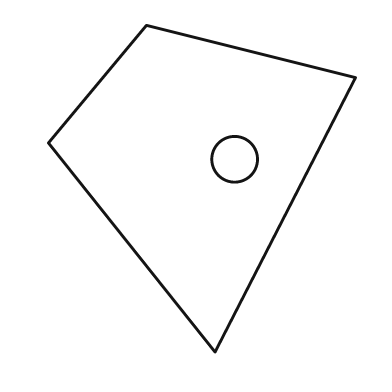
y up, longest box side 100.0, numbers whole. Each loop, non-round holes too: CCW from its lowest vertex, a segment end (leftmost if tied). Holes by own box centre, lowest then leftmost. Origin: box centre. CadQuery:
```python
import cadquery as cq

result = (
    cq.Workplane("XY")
    .moveTo(4.0, -50.0)
    .lineTo(47.0, 34.0)
    .lineTo(-17.0, 50.0)
    .lineTo(-47.0, 14.0)
    .close()
    .moveTo(10.0, 9.0)
    .circle(7.0)
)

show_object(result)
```